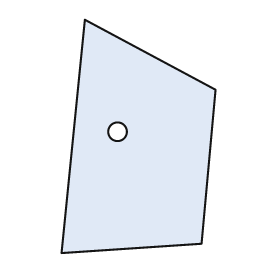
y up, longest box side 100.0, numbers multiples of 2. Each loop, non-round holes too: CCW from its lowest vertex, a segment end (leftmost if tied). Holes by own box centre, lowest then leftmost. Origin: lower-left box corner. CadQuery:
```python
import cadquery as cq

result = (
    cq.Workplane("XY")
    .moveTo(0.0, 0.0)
    .lineTo(60.0, 4.0)
    .lineTo(66.0, 70.0)
    .lineTo(10.0, 100.0)
    .close()
    .moveTo(24.0, 52.0)
    .circle(4.0)
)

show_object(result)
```